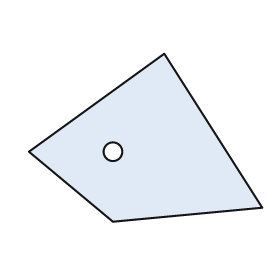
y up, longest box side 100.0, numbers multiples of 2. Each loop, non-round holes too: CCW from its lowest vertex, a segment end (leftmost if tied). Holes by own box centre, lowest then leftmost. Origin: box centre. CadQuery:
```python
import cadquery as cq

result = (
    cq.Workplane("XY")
    .moveTo(-14.0, -36.0)
    .lineTo(50.0, -30.0)
    .lineTo(8.0, 36.0)
    .lineTo(-50.0, -6.0)
    .close()
    .moveTo(-14.0, -6.0)
    .circle(4.0)
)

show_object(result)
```